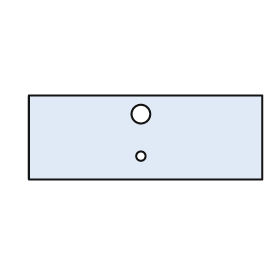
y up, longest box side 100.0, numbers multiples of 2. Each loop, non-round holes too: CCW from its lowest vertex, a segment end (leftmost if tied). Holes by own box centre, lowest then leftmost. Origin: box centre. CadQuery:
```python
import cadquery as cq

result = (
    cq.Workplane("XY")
    .moveTo(-50.0, -18.0)
    .lineTo(50.0, -18.0)
    .lineTo(50.0, 18.0)
    .lineTo(-50.0, 18.0)
    .close()
    .moveTo(-2.0, -8.0)
    .circle(2.0)
    .moveTo(-2.0, 10.0)
    .circle(4.0)
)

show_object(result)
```